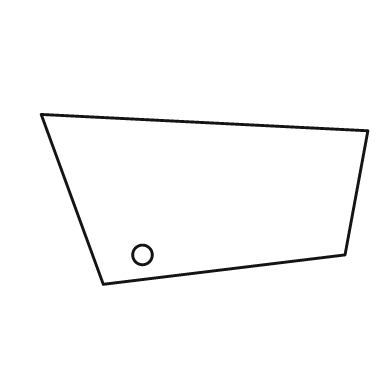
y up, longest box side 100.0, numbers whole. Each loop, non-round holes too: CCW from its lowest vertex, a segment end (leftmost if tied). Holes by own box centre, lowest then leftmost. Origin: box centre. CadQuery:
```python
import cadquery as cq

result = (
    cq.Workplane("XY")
    .moveTo(-31.0, -26.0)
    .lineTo(43.0, -17.0)
    .lineTo(50.0, 21.0)
    .lineTo(-50.0, 26.0)
    .close()
    .moveTo(-19.0, -17.0)
    .circle(3.0)
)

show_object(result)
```